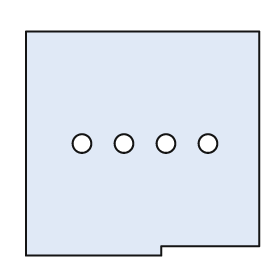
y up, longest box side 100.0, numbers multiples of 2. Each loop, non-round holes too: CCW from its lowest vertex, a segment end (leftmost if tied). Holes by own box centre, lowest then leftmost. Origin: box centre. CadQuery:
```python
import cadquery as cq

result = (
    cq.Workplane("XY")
    .moveTo(-50.0, -48.0)
    .lineTo(8.0, -48.0)
    .lineTo(8.0, -44.0)
    .lineTo(50.0, -44.0)
    .lineTo(50.0, 48.0)
    .lineTo(-50.0, 48.0)
    .close()
    .moveTo(-26.0, 0.0)
    .circle(4.0)
    .moveTo(-8.0, 0.0)
    .circle(4.0)
    .moveTo(10.0, 0.0)
    .circle(4.0)
    .moveTo(28.0, 0.0)
    .circle(4.0)
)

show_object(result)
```